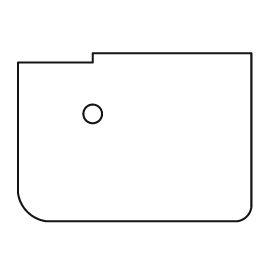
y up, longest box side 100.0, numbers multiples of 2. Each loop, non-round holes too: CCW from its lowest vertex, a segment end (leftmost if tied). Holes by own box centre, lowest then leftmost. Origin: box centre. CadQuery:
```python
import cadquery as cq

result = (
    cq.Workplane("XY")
    .moveTo(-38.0, -36.0)
    .lineTo(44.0, -36.0)
    .threePointArc((48.0, -34.0), (50.0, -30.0))
    .lineTo(50.0, 36.0)
    .lineTo(-18.0, 36.0)
    .lineTo(-18.0, 32.0)
    .lineTo(-50.0, 32.0)
    .lineTo(-50.0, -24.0)
    .threePointArc((-46.0, -32.0), (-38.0, -36.0))
    .close()
    .moveTo(-18.0, 10.0)
    .circle(4.0)
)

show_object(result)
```